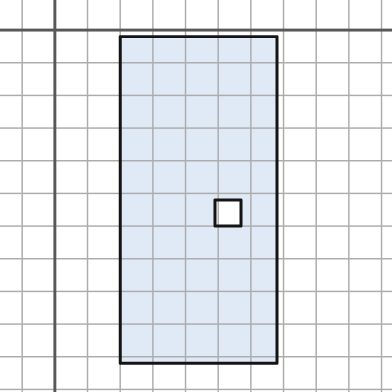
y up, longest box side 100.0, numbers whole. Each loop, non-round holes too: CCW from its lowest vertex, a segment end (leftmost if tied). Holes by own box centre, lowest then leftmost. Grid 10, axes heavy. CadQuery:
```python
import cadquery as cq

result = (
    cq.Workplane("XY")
    .moveTo(20.0, -102.0)
    .lineTo(68.0, -102.0)
    .lineTo(68.0, -2.0)
    .lineTo(20.0, -2.0)
    .close()
    .moveTo(49.0, -60.0)
    .lineTo(57.0, -60.0)
    .lineTo(57.0, -52.0)
    .lineTo(49.0, -52.0)
    .close()
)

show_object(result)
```